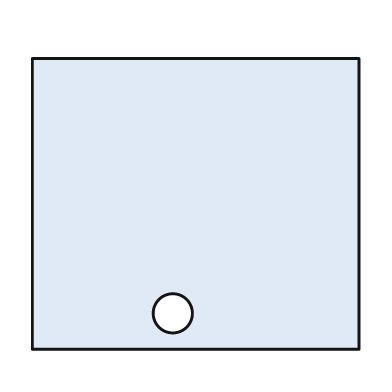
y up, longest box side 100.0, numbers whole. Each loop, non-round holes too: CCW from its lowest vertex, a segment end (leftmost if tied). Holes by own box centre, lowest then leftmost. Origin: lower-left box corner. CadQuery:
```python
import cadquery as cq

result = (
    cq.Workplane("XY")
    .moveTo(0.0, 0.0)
    .lineTo(100.0, 0.0)
    .lineTo(100.0, 89.0)
    .lineTo(0.0, 89.0)
    .close()
    .moveTo(43.0, 11.0)
    .circle(6.0)
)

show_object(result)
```